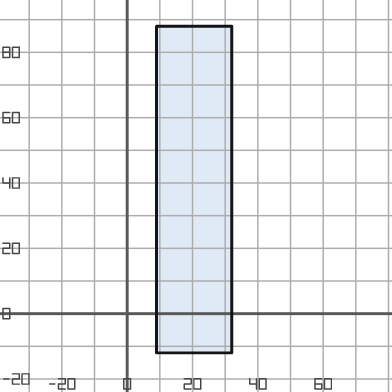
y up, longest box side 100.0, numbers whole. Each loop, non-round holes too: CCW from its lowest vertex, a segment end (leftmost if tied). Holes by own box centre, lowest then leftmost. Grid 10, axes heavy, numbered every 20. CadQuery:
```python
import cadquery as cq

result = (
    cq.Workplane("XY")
    .moveTo(9.0, -12.0)
    .lineTo(32.0, -12.0)
    .lineTo(32.0, 88.0)
    .lineTo(9.0, 88.0)
    .close()
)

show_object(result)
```